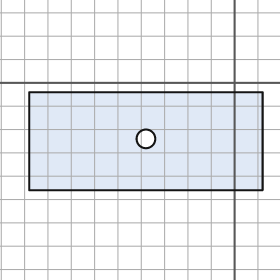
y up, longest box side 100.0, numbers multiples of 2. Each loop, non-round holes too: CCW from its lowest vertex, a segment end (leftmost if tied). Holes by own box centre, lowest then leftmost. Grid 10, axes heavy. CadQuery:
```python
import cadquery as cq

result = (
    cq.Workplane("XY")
    .moveTo(-88.0, -46.0)
    .lineTo(12.0, -46.0)
    .lineTo(12.0, -4.0)
    .lineTo(-88.0, -4.0)
    .close()
    .moveTo(-38.0, -24.0)
    .circle(4.0)
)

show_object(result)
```